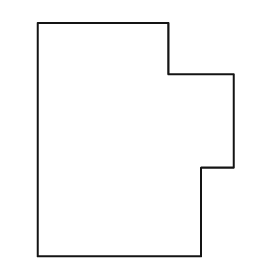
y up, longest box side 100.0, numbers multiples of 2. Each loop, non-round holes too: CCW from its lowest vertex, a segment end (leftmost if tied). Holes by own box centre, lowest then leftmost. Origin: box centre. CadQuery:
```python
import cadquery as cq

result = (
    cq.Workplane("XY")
    .moveTo(-42.0, -50.0)
    .lineTo(28.0, -50.0)
    .lineTo(28.0, -12.0)
    .lineTo(42.0, -12.0)
    .lineTo(42.0, 28.0)
    .lineTo(14.0, 28.0)
    .lineTo(14.0, 50.0)
    .lineTo(-42.0, 50.0)
    .close()
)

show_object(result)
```